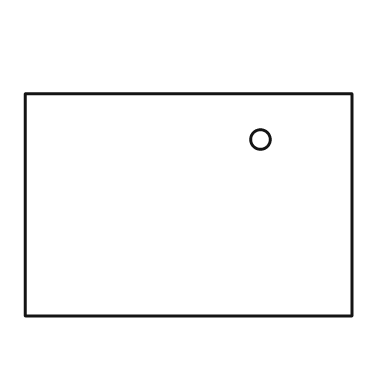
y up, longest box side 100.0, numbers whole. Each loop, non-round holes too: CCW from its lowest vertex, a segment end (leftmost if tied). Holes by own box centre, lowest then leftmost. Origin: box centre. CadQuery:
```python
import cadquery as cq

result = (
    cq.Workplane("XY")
    .moveTo(-50.0, -34.0)
    .lineTo(50.0, -34.0)
    .lineTo(50.0, 34.0)
    .lineTo(-50.0, 34.0)
    .close()
    .moveTo(22.0, 20.0)
    .circle(3.0)
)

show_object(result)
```